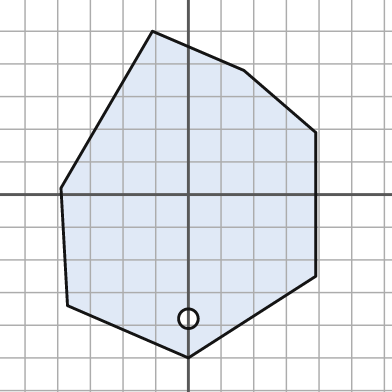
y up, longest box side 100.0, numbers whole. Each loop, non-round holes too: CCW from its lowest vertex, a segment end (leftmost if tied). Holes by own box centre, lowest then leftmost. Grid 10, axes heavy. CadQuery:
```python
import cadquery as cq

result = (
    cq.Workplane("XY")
    .moveTo(0.0, -50.0)
    .lineTo(39.0, -25.0)
    .lineTo(39.0, 19.0)
    .lineTo(17.0, 38.0)
    .lineTo(-11.0, 50.0)
    .lineTo(-39.0, 2.0)
    .lineTo(-37.0, -34.0)
    .close()
    .moveTo(0.0, -38.0)
    .circle(3.0)
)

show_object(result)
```